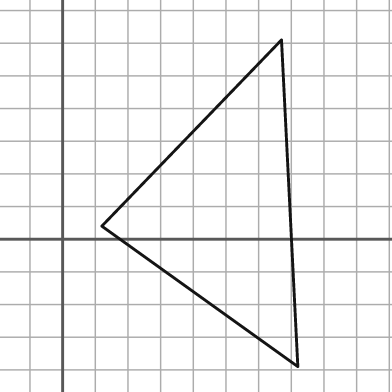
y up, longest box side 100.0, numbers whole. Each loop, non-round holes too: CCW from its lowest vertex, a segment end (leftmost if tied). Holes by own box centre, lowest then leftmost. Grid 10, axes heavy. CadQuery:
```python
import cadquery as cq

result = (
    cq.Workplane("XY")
    .moveTo(72.0, -39.0)
    .lineTo(67.0, 61.0)
    .lineTo(12.0, 4.0)
    .close()
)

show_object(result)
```